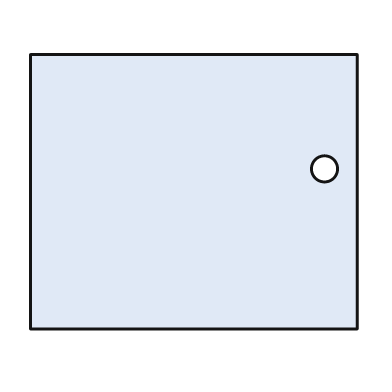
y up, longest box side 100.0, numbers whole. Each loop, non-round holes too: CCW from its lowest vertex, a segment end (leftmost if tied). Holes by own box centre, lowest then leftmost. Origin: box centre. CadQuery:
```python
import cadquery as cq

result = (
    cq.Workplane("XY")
    .moveTo(-50.0, -42.0)
    .lineTo(50.0, -42.0)
    .lineTo(50.0, 42.0)
    .lineTo(-50.0, 42.0)
    .close()
    .moveTo(40.0, 7.0)
    .circle(4.0)
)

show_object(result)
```